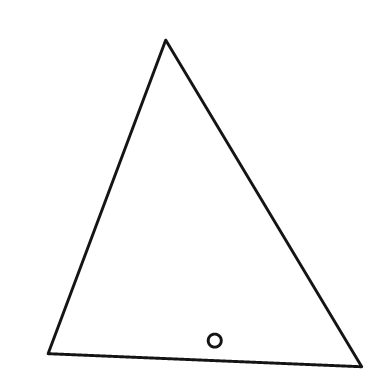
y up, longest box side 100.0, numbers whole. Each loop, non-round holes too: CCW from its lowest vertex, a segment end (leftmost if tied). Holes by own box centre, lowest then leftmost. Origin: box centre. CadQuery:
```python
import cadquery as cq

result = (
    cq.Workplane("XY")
    .moveTo(48.0, -50.0)
    .lineTo(-12.0, 50.0)
    .lineTo(-48.0, -46.0)
    .close()
    .moveTo(3.0, -42.0)
    .circle(2.0)
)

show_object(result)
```